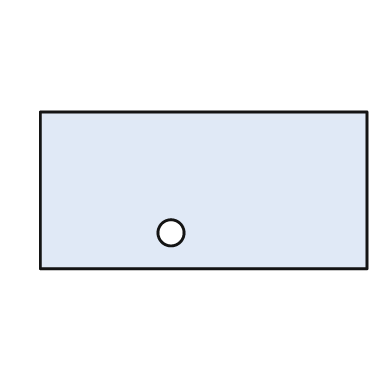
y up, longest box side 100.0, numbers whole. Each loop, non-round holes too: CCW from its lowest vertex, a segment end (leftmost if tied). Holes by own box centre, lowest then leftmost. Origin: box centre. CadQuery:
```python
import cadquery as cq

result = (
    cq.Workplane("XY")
    .moveTo(-50.0, -24.0)
    .lineTo(50.0, -24.0)
    .lineTo(50.0, 24.0)
    .lineTo(-50.0, 24.0)
    .close()
    .moveTo(-10.0, -13.0)
    .circle(4.0)
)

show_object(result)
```